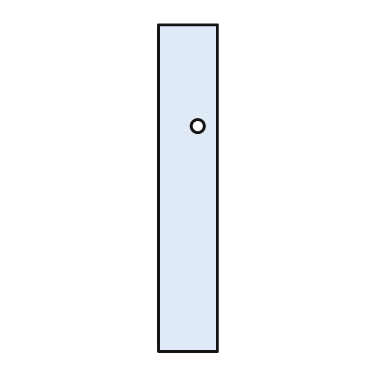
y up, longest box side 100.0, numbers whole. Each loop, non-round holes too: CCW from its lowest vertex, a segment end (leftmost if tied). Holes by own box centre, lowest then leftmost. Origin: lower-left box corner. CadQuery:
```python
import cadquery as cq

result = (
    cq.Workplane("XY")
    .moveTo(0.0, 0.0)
    .lineTo(18.0, 0.0)
    .lineTo(18.0, 100.0)
    .lineTo(0.0, 100.0)
    .close()
    .moveTo(12.0, 69.0)
    .circle(2.0)
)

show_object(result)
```